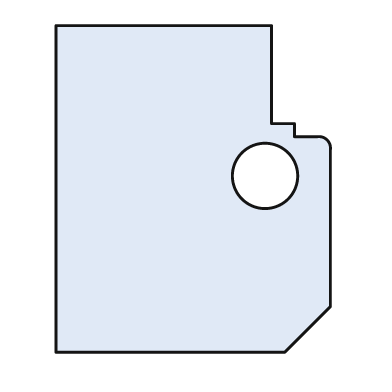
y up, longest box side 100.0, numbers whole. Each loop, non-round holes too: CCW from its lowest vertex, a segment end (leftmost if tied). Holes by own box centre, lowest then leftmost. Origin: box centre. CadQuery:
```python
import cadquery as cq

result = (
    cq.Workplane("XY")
    .moveTo(-42.0, -50.0)
    .lineTo(28.0, -50.0)
    .lineTo(42.0, -36.0)
    .lineTo(42.0, 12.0)
    .threePointArc((41.0, 15.0), (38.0, 16.0))
    .lineTo(31.0, 16.0)
    .lineTo(31.0, 20.0)
    .lineTo(24.0, 20.0)
    .lineTo(24.0, 50.0)
    .lineTo(-42.0, 50.0)
    .close()
    .moveTo(22.0, 4.0)
    .circle(10.0)
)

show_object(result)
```